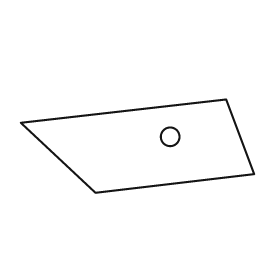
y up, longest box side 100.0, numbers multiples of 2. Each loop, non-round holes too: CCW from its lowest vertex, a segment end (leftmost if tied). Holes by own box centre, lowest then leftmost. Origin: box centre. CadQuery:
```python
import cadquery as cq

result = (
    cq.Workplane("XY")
    .moveTo(-18.0, -20.0)
    .lineTo(50.0, -12.0)
    .lineTo(38.0, 20.0)
    .lineTo(-50.0, 10.0)
    .close()
    .moveTo(14.0, 4.0)
    .circle(4.0)
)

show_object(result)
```